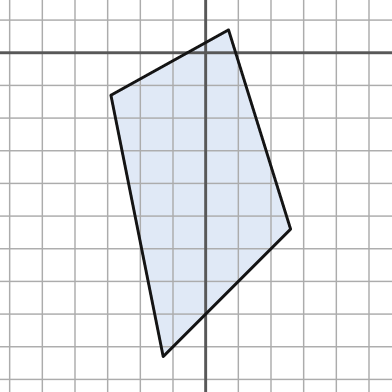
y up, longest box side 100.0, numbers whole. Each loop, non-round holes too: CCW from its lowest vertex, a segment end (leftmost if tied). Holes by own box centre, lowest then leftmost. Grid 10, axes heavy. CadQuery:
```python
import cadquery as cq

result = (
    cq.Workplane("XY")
    .moveTo(-13.0, -93.0)
    .lineTo(26.0, -54.0)
    .lineTo(7.0, 7.0)
    .lineTo(-29.0, -13.0)
    .close()
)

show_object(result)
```